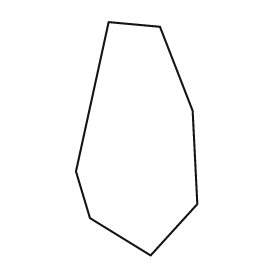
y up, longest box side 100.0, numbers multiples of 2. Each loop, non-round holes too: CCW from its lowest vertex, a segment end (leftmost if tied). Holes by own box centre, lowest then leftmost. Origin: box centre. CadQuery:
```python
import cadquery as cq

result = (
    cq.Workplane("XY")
    .moveTo(6.0, -50.0)
    .lineTo(26.0, -28.0)
    .lineTo(24.0, 12.0)
    .lineTo(10.0, 48.0)
    .lineTo(-12.0, 50.0)
    .lineTo(-26.0, -14.0)
    .lineTo(-20.0, -34.0)
    .close()
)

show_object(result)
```